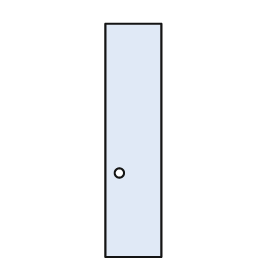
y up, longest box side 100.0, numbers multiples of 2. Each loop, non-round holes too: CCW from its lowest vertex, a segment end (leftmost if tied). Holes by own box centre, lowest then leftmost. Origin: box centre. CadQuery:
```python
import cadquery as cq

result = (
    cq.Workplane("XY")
    .moveTo(-12.0, -50.0)
    .lineTo(12.0, -50.0)
    .lineTo(12.0, 50.0)
    .lineTo(-12.0, 50.0)
    .close()
    .moveTo(-6.0, -14.0)
    .circle(2.0)
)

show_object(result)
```